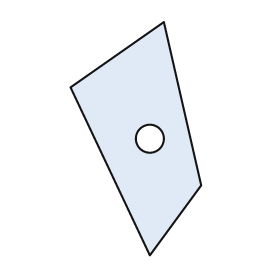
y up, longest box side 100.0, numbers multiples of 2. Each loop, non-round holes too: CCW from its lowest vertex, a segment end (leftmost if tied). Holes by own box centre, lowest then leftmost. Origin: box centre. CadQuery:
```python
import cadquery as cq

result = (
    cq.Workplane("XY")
    .moveTo(6.0, -50.0)
    .lineTo(28.0, -20.0)
    .lineTo(12.0, 50.0)
    .lineTo(-28.0, 22.0)
    .close()
    .moveTo(6.0, 0.0)
    .circle(6.0)
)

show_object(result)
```